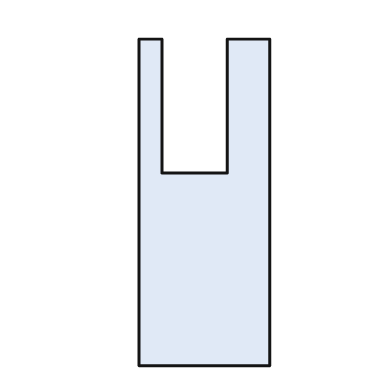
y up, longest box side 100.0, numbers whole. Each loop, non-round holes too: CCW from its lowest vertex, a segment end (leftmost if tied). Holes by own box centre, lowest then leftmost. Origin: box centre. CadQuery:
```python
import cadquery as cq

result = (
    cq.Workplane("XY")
    .moveTo(-20.0, -50.0)
    .lineTo(20.0, -50.0)
    .lineTo(20.0, 50.0)
    .lineTo(7.0, 50.0)
    .lineTo(7.0, 9.0)
    .lineTo(-13.0, 9.0)
    .lineTo(-13.0, 50.0)
    .lineTo(-20.0, 50.0)
    .close()
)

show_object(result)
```